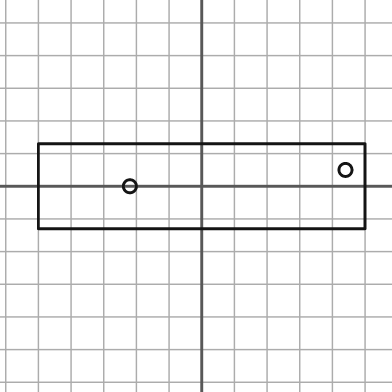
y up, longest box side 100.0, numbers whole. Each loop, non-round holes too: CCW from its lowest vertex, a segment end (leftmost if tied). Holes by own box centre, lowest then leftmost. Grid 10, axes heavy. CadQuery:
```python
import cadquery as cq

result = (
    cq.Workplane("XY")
    .moveTo(-50.0, -13.0)
    .lineTo(50.0, -13.0)
    .lineTo(50.0, 13.0)
    .lineTo(-50.0, 13.0)
    .close()
    .moveTo(-22.0, 0.0)
    .circle(2.0)
    .moveTo(44.0, 5.0)
    .circle(2.0)
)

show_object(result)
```